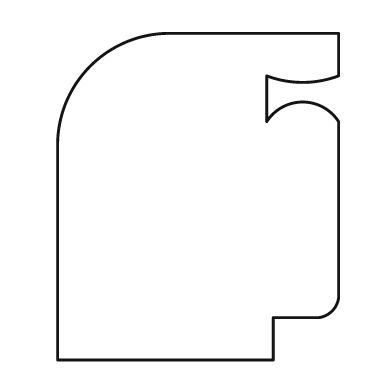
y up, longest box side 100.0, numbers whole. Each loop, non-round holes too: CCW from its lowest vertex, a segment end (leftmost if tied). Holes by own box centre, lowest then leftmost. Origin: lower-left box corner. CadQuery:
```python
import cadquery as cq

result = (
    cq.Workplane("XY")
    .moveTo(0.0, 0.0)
    .lineTo(66.0, 0.0)
    .lineTo(66.0, 13.0)
    .lineTo(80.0, 13.0)
    .threePointArc((84.0, 15.0), (86.0, 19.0))
    .lineTo(86.0, 73.0)
    .threePointArc((75.0, 79.0), (64.0, 73.0))
    .lineTo(64.0, 87.0)
    .threePointArc((75.0, 85.0), (86.0, 87.0))
    .lineTo(86.0, 100.0)
    .lineTo(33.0, 100.0)
    .threePointArc((10.0, 90.0), (0.0, 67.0))
    .close()
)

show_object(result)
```